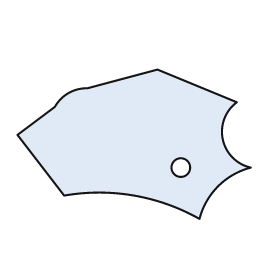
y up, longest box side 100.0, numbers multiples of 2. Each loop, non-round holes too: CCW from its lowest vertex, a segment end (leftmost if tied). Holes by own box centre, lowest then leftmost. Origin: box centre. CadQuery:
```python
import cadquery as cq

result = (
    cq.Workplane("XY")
    .moveTo(28.0, -32.0)
    .threePointArc((36.0, -18.0), (50.0, -10.0))
    .threePointArc((38.0, 2.0), (44.0, 18.0))
    .lineTo(10.0, 32.0)
    .lineTo(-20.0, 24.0)
    .threePointArc((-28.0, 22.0), (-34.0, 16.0))
    .lineTo(-50.0, 4.0)
    .lineTo(-30.0, -22.0)
    .threePointArc((0.0, -22.0), (28.0, -32.0))
    .close()
    .moveTo(20.0, -10.0)
    .circle(4.0)
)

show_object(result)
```